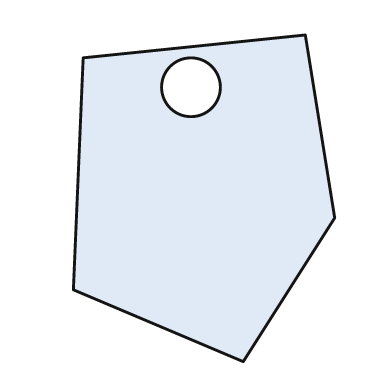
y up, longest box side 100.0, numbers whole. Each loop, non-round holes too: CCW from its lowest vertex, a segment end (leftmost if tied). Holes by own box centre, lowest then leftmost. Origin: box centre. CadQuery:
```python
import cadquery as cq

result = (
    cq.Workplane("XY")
    .moveTo(12.0, -50.0)
    .lineTo(40.0, -6.0)
    .lineTo(31.0, 50.0)
    .lineTo(-37.0, 43.0)
    .lineTo(-40.0, -28.0)
    .close()
    .moveTo(-4.0, 34.0)
    .circle(9.0)
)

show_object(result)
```